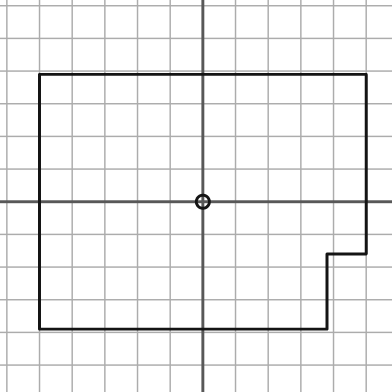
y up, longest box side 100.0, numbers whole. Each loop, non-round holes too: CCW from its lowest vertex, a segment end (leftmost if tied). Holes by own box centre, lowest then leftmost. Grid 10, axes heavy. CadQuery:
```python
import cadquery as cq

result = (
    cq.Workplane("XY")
    .moveTo(-50.0, -39.0)
    .lineTo(38.0, -39.0)
    .lineTo(38.0, -16.0)
    .lineTo(50.0, -16.0)
    .lineTo(50.0, 39.0)
    .lineTo(-50.0, 39.0)
    .close()
    .moveTo(0.0, 0.0)
    .circle(2.0)
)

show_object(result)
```